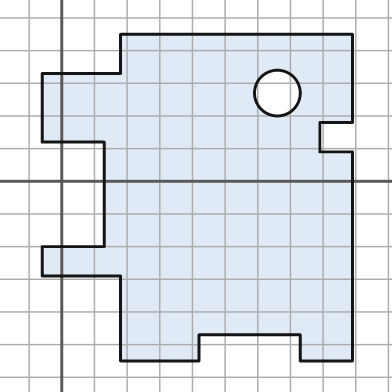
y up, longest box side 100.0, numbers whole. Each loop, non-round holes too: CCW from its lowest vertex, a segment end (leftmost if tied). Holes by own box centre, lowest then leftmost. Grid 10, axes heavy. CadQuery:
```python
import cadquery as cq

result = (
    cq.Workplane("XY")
    .moveTo(18.0, -55.0)
    .lineTo(42.0, -55.0)
    .lineTo(42.0, -47.0)
    .lineTo(73.0, -47.0)
    .lineTo(73.0, -55.0)
    .lineTo(89.0, -55.0)
    .lineTo(89.0, 9.0)
    .lineTo(79.0, 9.0)
    .lineTo(79.0, 18.0)
    .lineTo(89.0, 18.0)
    .lineTo(89.0, 45.0)
    .lineTo(18.0, 45.0)
    .lineTo(18.0, 33.0)
    .lineTo(-6.0, 33.0)
    .lineTo(-6.0, 12.0)
    .lineTo(13.0, 12.0)
    .lineTo(13.0, -20.0)
    .lineTo(-6.0, -20.0)
    .lineTo(-6.0, -29.0)
    .lineTo(18.0, -29.0)
    .close()
    .moveTo(66.0, 27.0)
    .circle(7.0)
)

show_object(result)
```